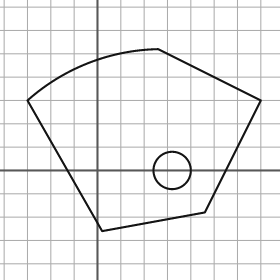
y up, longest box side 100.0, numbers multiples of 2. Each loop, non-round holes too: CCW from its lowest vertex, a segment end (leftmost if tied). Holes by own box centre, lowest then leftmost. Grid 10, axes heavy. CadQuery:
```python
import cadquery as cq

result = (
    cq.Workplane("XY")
    .moveTo(2.0, -26.0)
    .lineTo(46.0, -18.0)
    .lineTo(70.0, 30.0)
    .lineTo(26.0, 52.0)
    .threePointArc((-4.0, 46.0), (-30.0, 30.0))
    .close()
    .moveTo(32.0, 0.0)
    .circle(8.0)
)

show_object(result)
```